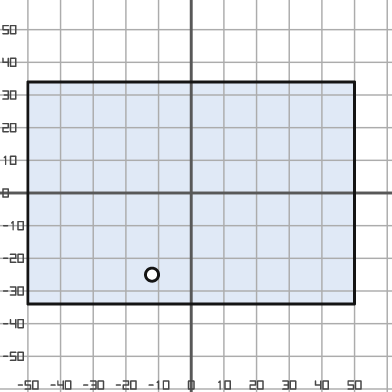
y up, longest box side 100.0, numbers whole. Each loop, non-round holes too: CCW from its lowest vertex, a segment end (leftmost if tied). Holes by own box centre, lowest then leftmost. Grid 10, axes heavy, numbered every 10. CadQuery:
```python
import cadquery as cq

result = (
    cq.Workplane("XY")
    .moveTo(-50.0, -34.0)
    .lineTo(50.0, -34.0)
    .lineTo(50.0, 34.0)
    .lineTo(-50.0, 34.0)
    .close()
    .moveTo(-12.0, -25.0)
    .circle(2.0)
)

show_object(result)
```